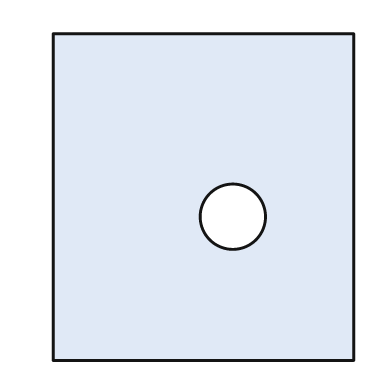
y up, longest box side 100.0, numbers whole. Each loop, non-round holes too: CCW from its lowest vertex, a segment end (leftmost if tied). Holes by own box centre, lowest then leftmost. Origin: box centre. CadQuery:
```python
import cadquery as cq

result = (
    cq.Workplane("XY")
    .moveTo(-46.0, -50.0)
    .lineTo(46.0, -50.0)
    .lineTo(46.0, 50.0)
    .lineTo(-46.0, 50.0)
    .close()
    .moveTo(9.0, -6.0)
    .circle(10.0)
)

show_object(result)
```